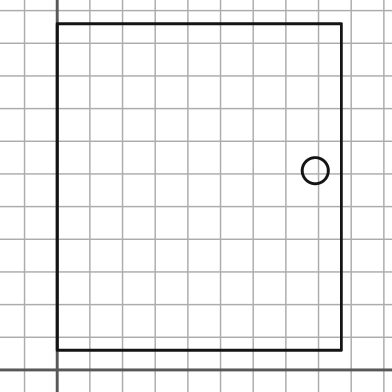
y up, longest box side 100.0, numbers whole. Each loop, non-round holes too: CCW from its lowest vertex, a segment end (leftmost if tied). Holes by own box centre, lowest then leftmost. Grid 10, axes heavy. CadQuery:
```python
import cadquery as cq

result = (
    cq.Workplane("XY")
    .moveTo(0.0, 6.0)
    .lineTo(87.0, 6.0)
    .lineTo(87.0, 106.0)
    .lineTo(0.0, 106.0)
    .close()
    .moveTo(79.0, 61.0)
    .circle(4.0)
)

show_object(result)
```